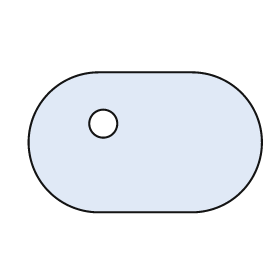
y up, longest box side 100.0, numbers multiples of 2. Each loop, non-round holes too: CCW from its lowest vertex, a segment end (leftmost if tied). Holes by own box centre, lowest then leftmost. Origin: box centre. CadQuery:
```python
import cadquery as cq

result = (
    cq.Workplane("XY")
    .moveTo(-20.0, -30.0)
    .lineTo(20.0, -30.0)
    .threePointArc((50.0, 0.0), (20.0, 30.0))
    .lineTo(-20.0, 30.0)
    .threePointArc((-50.0, 0.0), (-20.0, -30.0))
    .close()
    .moveTo(-18.0, 8.0)
    .circle(6.0)
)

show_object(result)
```